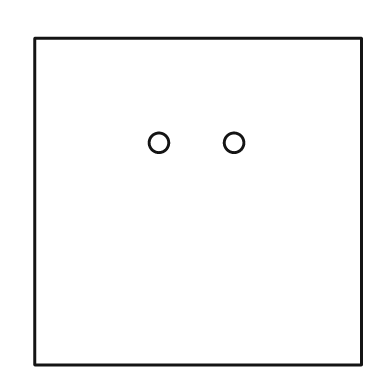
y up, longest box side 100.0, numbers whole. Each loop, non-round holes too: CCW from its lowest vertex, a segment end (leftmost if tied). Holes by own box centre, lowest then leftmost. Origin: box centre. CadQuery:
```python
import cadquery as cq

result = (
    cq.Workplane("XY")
    .moveTo(-50.0, -50.0)
    .lineTo(50.0, -50.0)
    .lineTo(50.0, 50.0)
    .lineTo(-50.0, 50.0)
    .close()
    .moveTo(-12.0, 18.0)
    .circle(3.0)
    .moveTo(11.0, 18.0)
    .circle(3.0)
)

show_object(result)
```